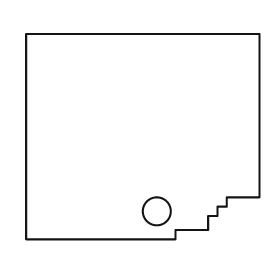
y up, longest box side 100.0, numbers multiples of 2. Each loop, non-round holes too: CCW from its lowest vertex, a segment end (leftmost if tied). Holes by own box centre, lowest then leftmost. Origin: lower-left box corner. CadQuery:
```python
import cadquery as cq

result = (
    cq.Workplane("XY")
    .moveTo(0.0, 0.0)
    .lineTo(64.0, 0.0)
    .lineTo(64.0, 4.0)
    .lineTo(78.0, 4.0)
    .lineTo(78.0, 10.0)
    .lineTo(82.0, 10.0)
    .lineTo(82.0, 14.0)
    .lineTo(86.0, 14.0)
    .lineTo(86.0, 18.0)
    .lineTo(100.0, 18.0)
    .lineTo(100.0, 88.0)
    .lineTo(0.0, 88.0)
    .close()
    .moveTo(56.0, 12.0)
    .circle(6.0)
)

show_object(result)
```